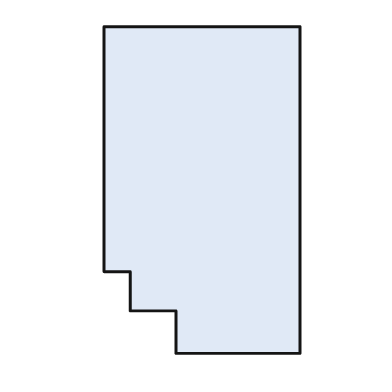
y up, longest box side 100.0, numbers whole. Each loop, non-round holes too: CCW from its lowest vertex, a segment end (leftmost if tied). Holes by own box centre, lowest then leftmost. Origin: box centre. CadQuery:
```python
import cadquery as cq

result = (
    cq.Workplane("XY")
    .moveTo(-8.0, -50.0)
    .lineTo(30.0, -50.0)
    .lineTo(30.0, 50.0)
    .lineTo(-30.0, 50.0)
    .lineTo(-30.0, -25.0)
    .lineTo(-22.0, -25.0)
    .lineTo(-22.0, -37.0)
    .lineTo(-8.0, -37.0)
    .close()
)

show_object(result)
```